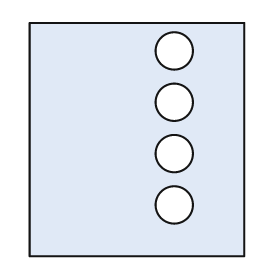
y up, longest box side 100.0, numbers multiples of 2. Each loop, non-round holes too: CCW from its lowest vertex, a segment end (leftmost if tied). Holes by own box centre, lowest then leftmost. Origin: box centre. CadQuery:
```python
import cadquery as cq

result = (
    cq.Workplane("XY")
    .moveTo(-46.0, -50.0)
    .lineTo(46.0, -50.0)
    .lineTo(46.0, 50.0)
    .lineTo(-46.0, 50.0)
    .close()
    .moveTo(16.0, -28.0)
    .circle(8.0)
    .moveTo(16.0, -6.0)
    .circle(8.0)
    .moveTo(16.0, 16.0)
    .circle(8.0)
    .moveTo(16.0, 38.0)
    .circle(8.0)
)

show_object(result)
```